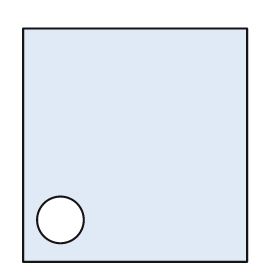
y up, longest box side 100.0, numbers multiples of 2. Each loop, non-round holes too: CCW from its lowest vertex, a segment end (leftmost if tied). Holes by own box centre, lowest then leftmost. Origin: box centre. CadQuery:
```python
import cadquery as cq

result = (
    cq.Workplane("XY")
    .moveTo(-48.0, -50.0)
    .lineTo(48.0, -50.0)
    .lineTo(48.0, 50.0)
    .lineTo(-48.0, 50.0)
    .close()
    .moveTo(-32.0, -32.0)
    .circle(10.0)
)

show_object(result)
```